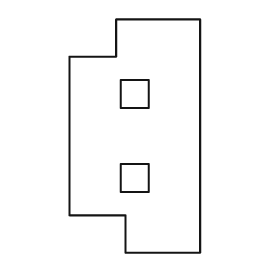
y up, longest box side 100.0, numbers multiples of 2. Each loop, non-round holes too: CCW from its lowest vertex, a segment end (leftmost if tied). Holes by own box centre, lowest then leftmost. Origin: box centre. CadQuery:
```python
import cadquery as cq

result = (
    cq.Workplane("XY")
    .moveTo(-4.0, -50.0)
    .lineTo(28.0, -50.0)
    .lineTo(28.0, 50.0)
    .lineTo(-8.0, 50.0)
    .lineTo(-8.0, 34.0)
    .lineTo(-28.0, 34.0)
    .lineTo(-28.0, -34.0)
    .lineTo(-4.0, -34.0)
    .close()
    .moveTo(-6.0, -24.0)
    .lineTo(6.0, -24.0)
    .lineTo(6.0, -12.0)
    .lineTo(-6.0, -12.0)
    .close()
    .moveTo(-6.0, 12.0)
    .lineTo(6.0, 12.0)
    .lineTo(6.0, 24.0)
    .lineTo(-6.0, 24.0)
    .close()
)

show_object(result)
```